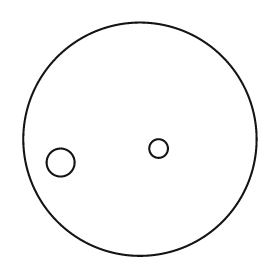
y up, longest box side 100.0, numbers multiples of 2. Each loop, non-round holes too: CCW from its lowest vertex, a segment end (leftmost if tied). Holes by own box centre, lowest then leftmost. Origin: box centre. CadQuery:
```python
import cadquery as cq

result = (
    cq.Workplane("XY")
    .moveTo(0.0, 0.0)
    .circle(50.0)
    .moveTo(-34.0, -10.0)
    .circle(6.0)
    .moveTo(8.0, -4.0)
    .circle(4.0)
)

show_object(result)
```